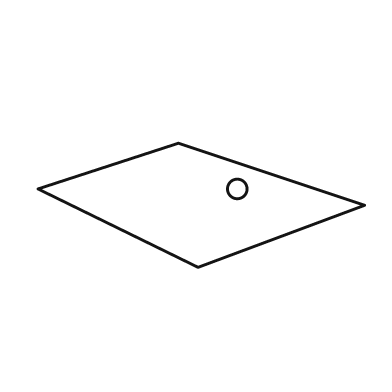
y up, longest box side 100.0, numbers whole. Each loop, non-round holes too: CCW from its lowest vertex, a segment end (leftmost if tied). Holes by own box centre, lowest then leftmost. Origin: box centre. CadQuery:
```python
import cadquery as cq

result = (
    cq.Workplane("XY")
    .moveTo(-1.0, -19.0)
    .lineTo(50.0, 0.0)
    .lineTo(-7.0, 19.0)
    .lineTo(-50.0, 5.0)
    .close()
    .moveTo(11.0, 5.0)
    .circle(3.0)
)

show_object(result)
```